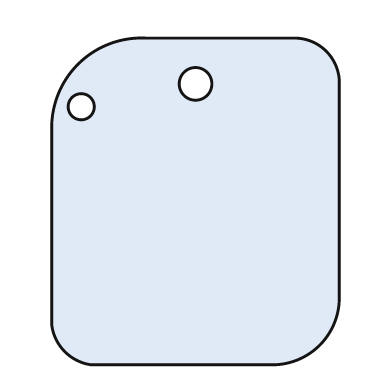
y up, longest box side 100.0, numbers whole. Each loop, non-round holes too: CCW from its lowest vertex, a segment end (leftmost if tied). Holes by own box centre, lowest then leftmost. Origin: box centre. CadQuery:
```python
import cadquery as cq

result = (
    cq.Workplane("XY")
    .moveTo(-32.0, -50.0)
    .lineTo(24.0, -50.0)
    .threePointArc((38.0, -44.0), (44.0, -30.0))
    .lineTo(44.0, 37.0)
    .threePointArc((40.0, 46.0), (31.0, 50.0))
    .lineTo(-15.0, 50.0)
    .threePointArc((-36.0, 42.0), (-44.0, 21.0))
    .lineTo(-44.0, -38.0)
    .threePointArc((-40.0, -46.0), (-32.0, -50.0))
    .close()
    .moveTo(-35.0, 29.0)
    .circle(4.0)
    .moveTo(0.0, 36.0)
    .circle(5.0)
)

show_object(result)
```